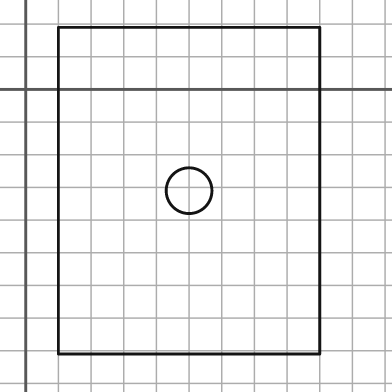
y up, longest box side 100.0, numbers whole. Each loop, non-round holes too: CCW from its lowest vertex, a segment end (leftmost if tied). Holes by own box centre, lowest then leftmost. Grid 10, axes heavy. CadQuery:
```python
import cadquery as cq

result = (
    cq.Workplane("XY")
    .moveTo(10.0, -81.0)
    .lineTo(90.0, -81.0)
    .lineTo(90.0, 19.0)
    .lineTo(10.0, 19.0)
    .close()
    .moveTo(50.0, -31.0)
    .circle(7.0)
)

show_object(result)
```